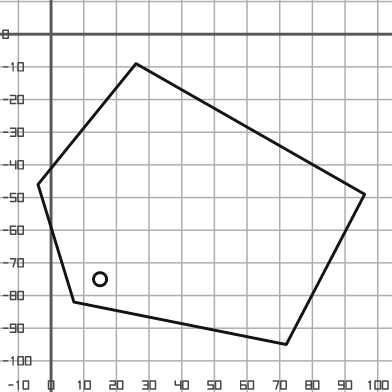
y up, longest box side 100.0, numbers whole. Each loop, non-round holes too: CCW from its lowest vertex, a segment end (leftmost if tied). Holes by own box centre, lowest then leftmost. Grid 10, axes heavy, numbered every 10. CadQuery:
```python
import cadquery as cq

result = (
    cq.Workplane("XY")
    .moveTo(72.0, -95.0)
    .lineTo(96.0, -49.0)
    .lineTo(26.0, -9.0)
    .lineTo(-4.0, -46.0)
    .lineTo(7.0, -82.0)
    .close()
    .moveTo(15.0, -75.0)
    .circle(2.0)
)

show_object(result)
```